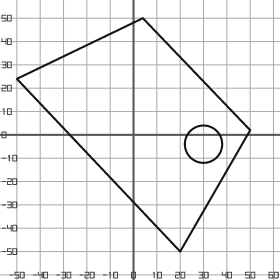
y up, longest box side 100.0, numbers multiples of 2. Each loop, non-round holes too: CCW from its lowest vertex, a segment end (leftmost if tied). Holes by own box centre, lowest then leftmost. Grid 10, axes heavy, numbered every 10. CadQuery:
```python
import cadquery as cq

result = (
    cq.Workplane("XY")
    .moveTo(20.0, -50.0)
    .lineTo(50.0, 2.0)
    .lineTo(4.0, 50.0)
    .lineTo(-50.0, 24.0)
    .close()
    .moveTo(30.0, -4.0)
    .circle(8.0)
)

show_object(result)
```